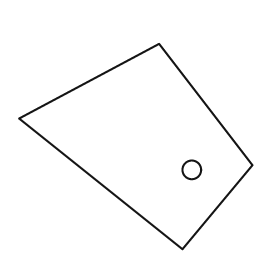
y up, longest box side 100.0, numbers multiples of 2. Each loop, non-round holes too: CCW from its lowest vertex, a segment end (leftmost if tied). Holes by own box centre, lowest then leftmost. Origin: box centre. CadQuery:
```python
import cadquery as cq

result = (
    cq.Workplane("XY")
    .moveTo(20.0, -44.0)
    .lineTo(50.0, -8.0)
    .lineTo(10.0, 44.0)
    .lineTo(-50.0, 12.0)
    .close()
    .moveTo(24.0, -10.0)
    .circle(4.0)
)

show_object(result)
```